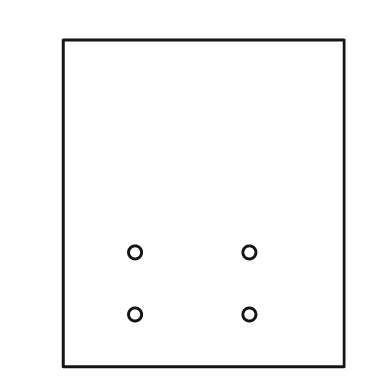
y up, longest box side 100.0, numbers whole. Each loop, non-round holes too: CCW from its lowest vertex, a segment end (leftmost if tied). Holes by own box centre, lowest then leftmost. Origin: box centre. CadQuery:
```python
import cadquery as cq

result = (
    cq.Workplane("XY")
    .moveTo(-43.0, -50.0)
    .lineTo(43.0, -50.0)
    .lineTo(43.0, 50.0)
    .lineTo(-43.0, 50.0)
    .close()
    .moveTo(-21.0, -34.0)
    .circle(2.0)
    .moveTo(14.0, -34.0)
    .circle(2.0)
    .moveTo(-21.0, -15.0)
    .circle(2.0)
    .moveTo(14.0, -15.0)
    .circle(2.0)
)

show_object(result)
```